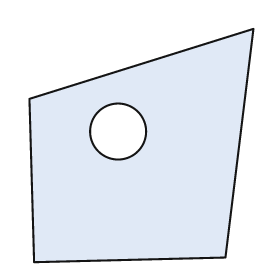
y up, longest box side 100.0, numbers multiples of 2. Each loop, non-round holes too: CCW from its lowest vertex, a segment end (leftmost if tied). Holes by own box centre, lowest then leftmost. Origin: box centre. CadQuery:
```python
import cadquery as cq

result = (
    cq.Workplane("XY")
    .moveTo(-46.0, -50.0)
    .lineTo(36.0, -48.0)
    .lineTo(48.0, 50.0)
    .lineTo(-48.0, 20.0)
    .close()
    .moveTo(-10.0, 6.0)
    .circle(12.0)
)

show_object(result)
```